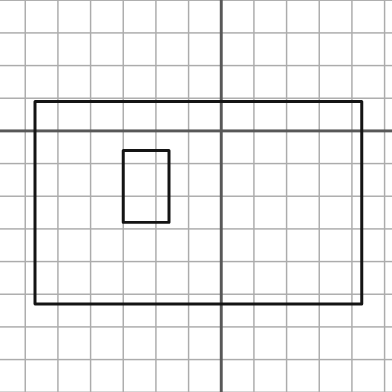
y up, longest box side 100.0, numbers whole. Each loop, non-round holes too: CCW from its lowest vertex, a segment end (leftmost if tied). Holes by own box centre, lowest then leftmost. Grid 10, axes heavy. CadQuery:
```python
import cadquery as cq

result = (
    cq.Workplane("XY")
    .moveTo(-57.0, -53.0)
    .lineTo(43.0, -53.0)
    .lineTo(43.0, 9.0)
    .lineTo(-57.0, 9.0)
    .close()
    .moveTo(-30.0, -28.0)
    .lineTo(-16.0, -28.0)
    .lineTo(-16.0, -6.0)
    .lineTo(-30.0, -6.0)
    .close()
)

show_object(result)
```